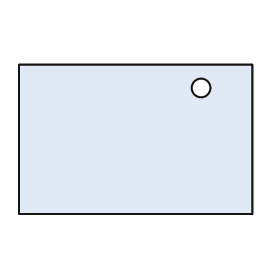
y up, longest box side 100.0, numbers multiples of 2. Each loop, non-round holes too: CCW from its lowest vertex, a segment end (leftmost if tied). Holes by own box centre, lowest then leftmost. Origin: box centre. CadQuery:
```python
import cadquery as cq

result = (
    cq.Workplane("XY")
    .moveTo(-50.0, -32.0)
    .lineTo(50.0, -32.0)
    .lineTo(50.0, 32.0)
    .lineTo(-50.0, 32.0)
    .close()
    .moveTo(28.0, 22.0)
    .circle(4.0)
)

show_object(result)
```